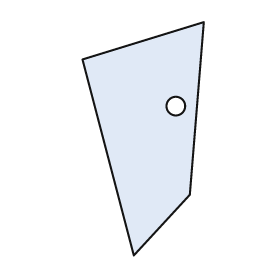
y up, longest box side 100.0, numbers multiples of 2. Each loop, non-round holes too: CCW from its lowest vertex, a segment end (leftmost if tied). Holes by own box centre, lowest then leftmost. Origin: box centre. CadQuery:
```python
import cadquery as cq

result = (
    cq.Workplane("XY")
    .moveTo(-4.0, -50.0)
    .lineTo(20.0, -24.0)
    .lineTo(26.0, 50.0)
    .lineTo(-26.0, 34.0)
    .close()
    .moveTo(14.0, 14.0)
    .circle(4.0)
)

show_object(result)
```